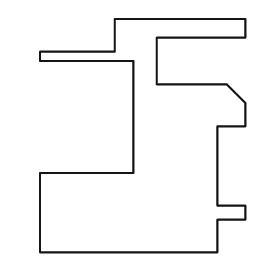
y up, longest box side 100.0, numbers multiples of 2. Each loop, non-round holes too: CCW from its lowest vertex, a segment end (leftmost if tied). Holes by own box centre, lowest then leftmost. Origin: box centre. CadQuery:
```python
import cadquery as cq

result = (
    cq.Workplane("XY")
    .moveTo(-44.0, -50.0)
    .lineTo(32.0, -50.0)
    .lineTo(32.0, -36.0)
    .lineTo(44.0, -36.0)
    .lineTo(44.0, -30.0)
    .lineTo(32.0, -30.0)
    .lineTo(32.0, 4.0)
    .lineTo(44.0, 4.0)
    .lineTo(44.0, 14.0)
    .lineTo(36.0, 22.0)
    .lineTo(6.0, 22.0)
    .lineTo(6.0, 42.0)
    .lineTo(44.0, 42.0)
    .lineTo(44.0, 50.0)
    .lineTo(-12.0, 50.0)
    .lineTo(-12.0, 36.0)
    .lineTo(-44.0, 36.0)
    .lineTo(-44.0, 32.0)
    .lineTo(-4.0, 32.0)
    .lineTo(-4.0, -16.0)
    .lineTo(-44.0, -16.0)
    .close()
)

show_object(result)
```